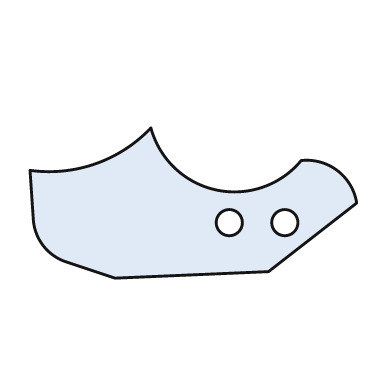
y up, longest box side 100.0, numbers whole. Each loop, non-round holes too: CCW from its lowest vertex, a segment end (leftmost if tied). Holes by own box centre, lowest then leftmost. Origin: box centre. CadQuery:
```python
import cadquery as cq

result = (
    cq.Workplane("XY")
    .moveTo(-24.0, -23.0)
    .lineTo(23.0, -21.0)
    .lineTo(50.0, 0.0)
    .threePointArc((44.0, 10.0), (33.0, 13.0))
    .threePointArc((7.0, 4.0), (-13.0, 23.0))
    .threePointArc((-30.0, 12.0), (-50.0, 10.0))
    .lineTo(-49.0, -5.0)
    .threePointArc((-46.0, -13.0), (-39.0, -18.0))
    .close()
    .moveTo(11.0, -6.0)
    .circle(4.0)
    .moveTo(28.0, -6.0)
    .circle(4.0)
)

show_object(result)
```